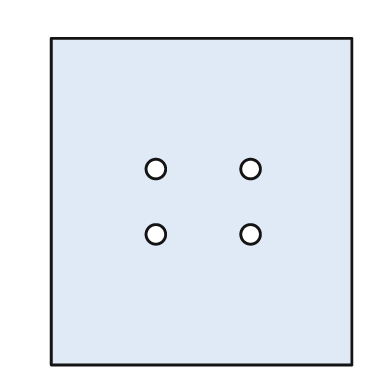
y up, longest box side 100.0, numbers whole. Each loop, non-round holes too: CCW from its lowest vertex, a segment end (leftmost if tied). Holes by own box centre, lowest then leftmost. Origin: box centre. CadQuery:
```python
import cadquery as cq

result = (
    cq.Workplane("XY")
    .moveTo(-46.0, -50.0)
    .lineTo(46.0, -50.0)
    .lineTo(46.0, 50.0)
    .lineTo(-46.0, 50.0)
    .close()
    .moveTo(-14.0, -10.0)
    .circle(3.0)
    .moveTo(15.0, -10.0)
    .circle(3.0)
    .moveTo(-14.0, 10.0)
    .circle(3.0)
    .moveTo(15.0, 10.0)
    .circle(3.0)
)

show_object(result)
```